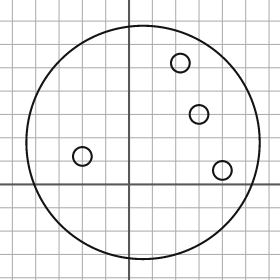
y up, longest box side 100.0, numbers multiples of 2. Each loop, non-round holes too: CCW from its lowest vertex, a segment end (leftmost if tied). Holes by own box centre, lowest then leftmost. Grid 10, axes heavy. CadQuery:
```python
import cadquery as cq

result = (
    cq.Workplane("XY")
    .moveTo(6.0, 18.0)
    .circle(50.0)
    .moveTo(40.0, 6.0)
    .circle(4.0)
    .moveTo(-20.0, 12.0)
    .circle(4.0)
    .moveTo(30.0, 30.0)
    .circle(4.0)
    .moveTo(22.0, 52.0)
    .circle(4.0)
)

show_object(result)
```